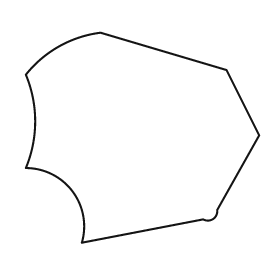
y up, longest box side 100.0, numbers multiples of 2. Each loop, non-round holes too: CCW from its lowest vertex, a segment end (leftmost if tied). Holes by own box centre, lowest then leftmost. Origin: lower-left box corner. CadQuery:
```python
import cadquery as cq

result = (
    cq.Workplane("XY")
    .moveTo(24.0, 0.0)
    .lineTo(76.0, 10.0)
    .threePointArc((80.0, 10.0), (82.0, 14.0))
    .lineTo(100.0, 46.0)
    .lineTo(86.0, 74.0)
    .lineTo(32.0, 90.0)
    .threePointArc((14.0, 84.0), (0.0, 72.0))
    .threePointArc((4.0, 52.0), (0.0, 32.0))
    .threePointArc((20.0, 22.0), (24.0, 0.0))
    .close()
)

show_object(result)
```